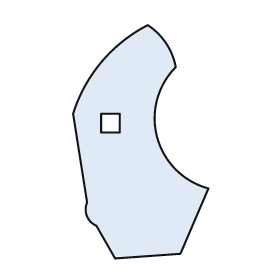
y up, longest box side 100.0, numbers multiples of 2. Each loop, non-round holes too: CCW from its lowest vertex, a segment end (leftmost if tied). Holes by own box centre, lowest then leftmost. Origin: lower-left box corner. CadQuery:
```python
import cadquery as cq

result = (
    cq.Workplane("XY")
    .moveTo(18.0, 0.0)
    .lineTo(46.0, 2.0)
    .lineTo(58.0, 30.0)
    .threePointArc((36.0, 52.0), (44.0, 82.0))
    .threePointArc((40.0, 92.0), (32.0, 100.0))
    .threePointArc((12.0, 84.0), (0.0, 62.0))
    .lineTo(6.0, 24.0)
    .threePointArc((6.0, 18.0), (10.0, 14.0))
    .close()
    .moveTo(12.0, 54.0)
    .lineTo(20.0, 54.0)
    .lineTo(20.0, 62.0)
    .lineTo(12.0, 62.0)
    .close()
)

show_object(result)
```